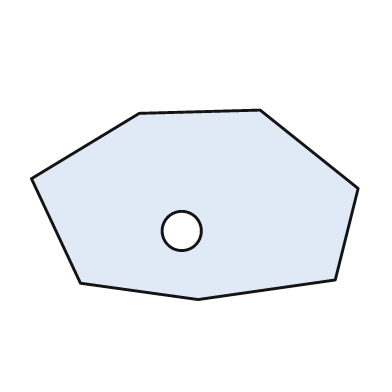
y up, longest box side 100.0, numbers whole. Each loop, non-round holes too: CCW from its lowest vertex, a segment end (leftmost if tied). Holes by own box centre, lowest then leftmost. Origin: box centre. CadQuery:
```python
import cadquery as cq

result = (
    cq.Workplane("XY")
    .moveTo(1.0, -29.0)
    .lineTo(43.0, -23.0)
    .lineTo(50.0, 5.0)
    .lineTo(20.0, 29.0)
    .lineTo(-17.0, 28.0)
    .lineTo(-50.0, 8.0)
    .lineTo(-35.0, -24.0)
    .close()
    .moveTo(-4.0, -8.0)
    .circle(6.0)
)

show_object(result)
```